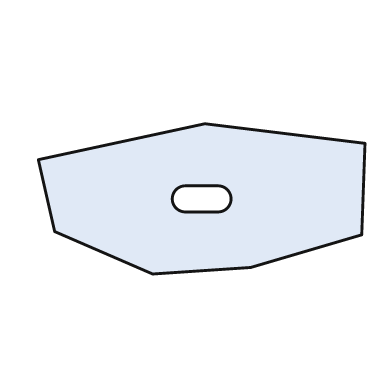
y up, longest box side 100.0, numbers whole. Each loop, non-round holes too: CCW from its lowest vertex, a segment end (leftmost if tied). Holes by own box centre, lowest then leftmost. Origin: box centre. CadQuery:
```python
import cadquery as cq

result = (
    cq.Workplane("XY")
    .moveTo(-15.0, -23.0)
    .lineTo(15.0, -21.0)
    .lineTo(49.0, -11.0)
    .lineTo(50.0, 17.0)
    .lineTo(1.0, 23.0)
    .lineTo(-50.0, 12.0)
    .lineTo(-45.0, -10.0)
    .close()
    .moveTo(-5.0, -4.0)
    .lineTo(5.0, -4.0)
    .threePointArc((9.0, 0.0), (5.0, 4.0))
    .lineTo(-5.0, 4.0)
    .threePointArc((-9.0, 0.0), (-5.0, -4.0))
    .close()
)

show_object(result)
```